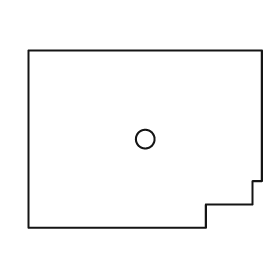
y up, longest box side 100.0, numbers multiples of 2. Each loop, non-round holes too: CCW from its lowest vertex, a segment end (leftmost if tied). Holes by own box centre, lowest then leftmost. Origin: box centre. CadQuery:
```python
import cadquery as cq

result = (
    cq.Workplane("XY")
    .moveTo(-50.0, -38.0)
    .lineTo(26.0, -38.0)
    .lineTo(26.0, -28.0)
    .lineTo(46.0, -28.0)
    .lineTo(46.0, -18.0)
    .lineTo(50.0, -18.0)
    .lineTo(50.0, 38.0)
    .lineTo(-50.0, 38.0)
    .close()
    .moveTo(0.0, 0.0)
    .circle(4.0)
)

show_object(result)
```